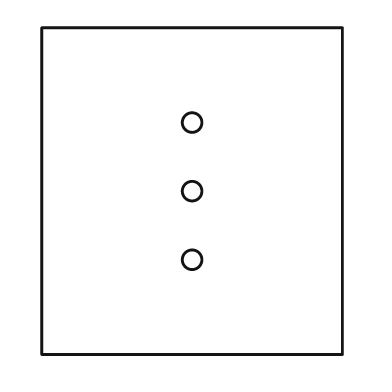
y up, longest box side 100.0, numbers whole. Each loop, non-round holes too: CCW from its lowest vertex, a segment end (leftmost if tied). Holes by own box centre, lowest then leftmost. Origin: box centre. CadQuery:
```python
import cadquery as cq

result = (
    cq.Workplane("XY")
    .moveTo(-46.0, -50.0)
    .lineTo(46.0, -50.0)
    .lineTo(46.0, 50.0)
    .lineTo(-46.0, 50.0)
    .close()
    .moveTo(0.0, -21.0)
    .circle(3.0)
    .moveTo(0.0, 0.0)
    .circle(3.0)
    .moveTo(0.0, 21.0)
    .circle(3.0)
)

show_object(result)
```